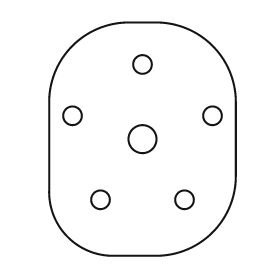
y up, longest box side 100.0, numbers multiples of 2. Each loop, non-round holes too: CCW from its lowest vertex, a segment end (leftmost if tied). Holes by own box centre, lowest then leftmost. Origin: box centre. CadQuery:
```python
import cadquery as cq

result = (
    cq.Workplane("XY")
    .moveTo(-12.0, -50.0)
    .lineTo(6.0, -50.0)
    .threePointArc((30.0, -40.0), (40.0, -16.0))
    .lineTo(40.0, 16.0)
    .threePointArc((30.0, 40.0), (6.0, 50.0))
    .lineTo(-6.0, 50.0)
    .threePointArc((-30.0, 40.0), (-40.0, 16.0))
    .lineTo(-40.0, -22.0)
    .threePointArc((-32.0, -42.0), (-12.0, -50.0))
    .close()
    .moveTo(-18.0, -26.0)
    .circle(4.0)
    .moveTo(18.0, -26.0)
    .circle(4.0)
    .moveTo(0.0, 0.0)
    .circle(6.0)
    .moveTo(-30.0, 10.0)
    .circle(4.0)
    .moveTo(30.0, 10.0)
    .circle(4.0)
    .moveTo(0.0, 32.0)
    .circle(4.0)
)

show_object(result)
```